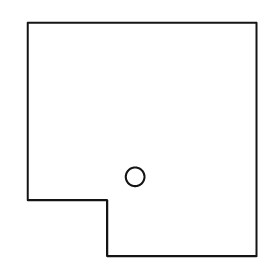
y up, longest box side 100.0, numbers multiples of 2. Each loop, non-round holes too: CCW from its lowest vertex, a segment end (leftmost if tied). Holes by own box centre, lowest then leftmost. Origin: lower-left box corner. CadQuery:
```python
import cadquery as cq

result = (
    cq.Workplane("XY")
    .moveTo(34.0, 0.0)
    .lineTo(98.0, 0.0)
    .lineTo(98.0, 100.0)
    .lineTo(0.0, 100.0)
    .lineTo(0.0, 24.0)
    .lineTo(34.0, 24.0)
    .close()
    .moveTo(46.0, 34.0)
    .circle(4.0)
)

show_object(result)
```